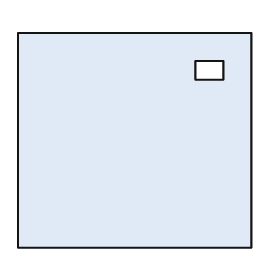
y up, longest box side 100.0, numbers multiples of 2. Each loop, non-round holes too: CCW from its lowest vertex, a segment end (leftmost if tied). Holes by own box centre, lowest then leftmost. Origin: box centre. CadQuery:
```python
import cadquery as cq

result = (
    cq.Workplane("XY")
    .moveTo(-50.0, -46.0)
    .lineTo(50.0, -46.0)
    .lineTo(50.0, 46.0)
    .lineTo(-50.0, 46.0)
    .close()
    .moveTo(26.0, 26.0)
    .lineTo(38.0, 26.0)
    .lineTo(38.0, 34.0)
    .lineTo(26.0, 34.0)
    .close()
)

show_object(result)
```